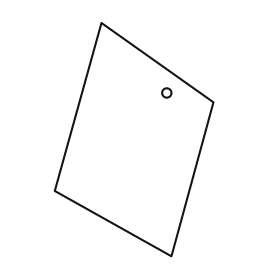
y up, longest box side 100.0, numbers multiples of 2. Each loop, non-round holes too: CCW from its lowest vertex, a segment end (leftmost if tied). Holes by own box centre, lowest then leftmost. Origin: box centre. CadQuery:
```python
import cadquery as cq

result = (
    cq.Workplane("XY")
    .moveTo(16.0, -50.0)
    .lineTo(34.0, 16.0)
    .lineTo(-14.0, 50.0)
    .lineTo(-34.0, -22.0)
    .close()
    .moveTo(14.0, 20.0)
    .circle(2.0)
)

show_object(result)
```